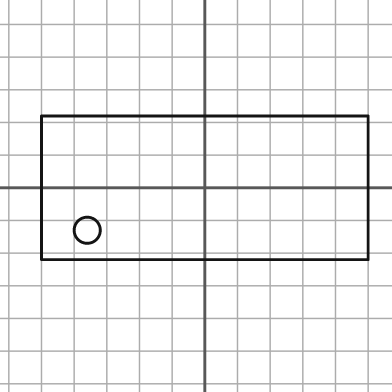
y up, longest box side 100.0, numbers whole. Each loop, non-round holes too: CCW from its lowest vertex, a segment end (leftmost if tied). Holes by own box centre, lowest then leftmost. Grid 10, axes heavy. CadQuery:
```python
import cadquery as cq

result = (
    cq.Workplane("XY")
    .moveTo(-50.0, -22.0)
    .lineTo(50.0, -22.0)
    .lineTo(50.0, 22.0)
    .lineTo(-50.0, 22.0)
    .close()
    .moveTo(-36.0, -13.0)
    .circle(4.0)
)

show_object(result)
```